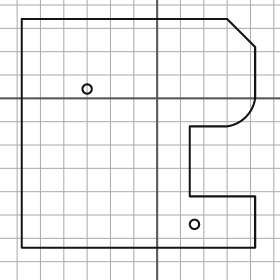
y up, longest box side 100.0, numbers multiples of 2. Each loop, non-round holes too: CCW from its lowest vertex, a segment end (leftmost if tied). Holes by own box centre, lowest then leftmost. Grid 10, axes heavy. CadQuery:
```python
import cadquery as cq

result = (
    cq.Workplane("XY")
    .moveTo(-58.0, -64.0)
    .lineTo(42.0, -64.0)
    .lineTo(42.0, -42.0)
    .lineTo(14.0, -42.0)
    .lineTo(14.0, -12.0)
    .lineTo(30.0, -12.0)
    .threePointArc((38.0, -8.0), (42.0, 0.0))
    .lineTo(42.0, 22.0)
    .lineTo(30.0, 34.0)
    .lineTo(-58.0, 34.0)
    .close()
    .moveTo(16.0, -54.0)
    .circle(2.0)
    .moveTo(-30.0, 4.0)
    .circle(2.0)
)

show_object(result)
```